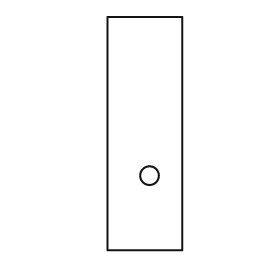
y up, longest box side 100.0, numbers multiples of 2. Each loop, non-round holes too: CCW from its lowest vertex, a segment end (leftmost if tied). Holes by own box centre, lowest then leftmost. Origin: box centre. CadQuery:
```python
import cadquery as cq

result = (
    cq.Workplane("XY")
    .moveTo(-16.0, -50.0)
    .lineTo(16.0, -50.0)
    .lineTo(16.0, 50.0)
    .lineTo(-16.0, 50.0)
    .close()
    .moveTo(2.0, -18.0)
    .circle(4.0)
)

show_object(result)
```